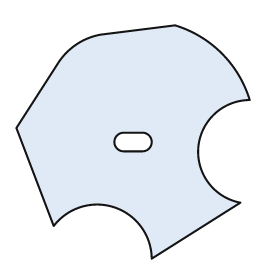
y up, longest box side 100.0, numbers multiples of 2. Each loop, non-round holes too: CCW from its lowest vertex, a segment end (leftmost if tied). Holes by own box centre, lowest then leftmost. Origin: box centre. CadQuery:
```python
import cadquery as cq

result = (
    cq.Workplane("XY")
    .moveTo(8.0, -50.0)
    .lineTo(46.0, -26.0)
    .threePointArc((28.0, -2.0), (50.0, 18.0))
    .threePointArc((38.0, 38.0), (18.0, 50.0))
    .lineTo(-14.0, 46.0)
    .threePointArc((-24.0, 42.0), (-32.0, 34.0))
    .lineTo(-50.0, 6.0)
    .lineTo(-34.0, -36.0)
    .threePointArc((-8.0, -28.0), (8.0, -50.0))
    .close()
    .moveTo(-4.0, -4.0)
    .lineTo(4.0, -4.0)
    .threePointArc((8.0, 0.0), (4.0, 4.0))
    .lineTo(-4.0, 4.0)
    .threePointArc((-8.0, 0.0), (-4.0, -4.0))
    .close()
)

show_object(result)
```